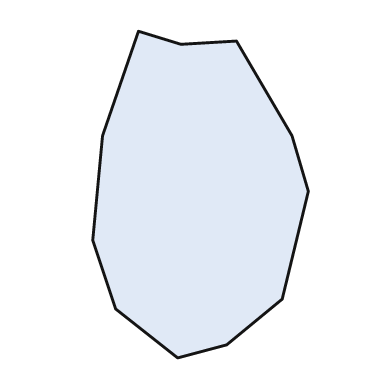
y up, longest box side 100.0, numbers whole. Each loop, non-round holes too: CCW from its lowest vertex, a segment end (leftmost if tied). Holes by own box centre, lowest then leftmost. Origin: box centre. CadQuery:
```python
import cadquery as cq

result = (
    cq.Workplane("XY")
    .moveTo(-7.0, -50.0)
    .lineTo(8.0, -46.0)
    .lineTo(25.0, -32.0)
    .lineTo(33.0, 1.0)
    .lineTo(28.0, 18.0)
    .lineTo(11.0, 47.0)
    .lineTo(-6.0, 46.0)
    .lineTo(-19.0, 50.0)
    .lineTo(-30.0, 18.0)
    .lineTo(-33.0, -14.0)
    .lineTo(-26.0, -35.0)
    .close()
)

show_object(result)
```